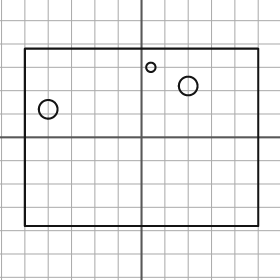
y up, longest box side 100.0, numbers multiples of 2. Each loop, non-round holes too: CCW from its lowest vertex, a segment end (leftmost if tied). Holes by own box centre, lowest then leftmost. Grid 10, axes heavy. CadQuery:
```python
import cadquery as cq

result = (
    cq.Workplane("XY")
    .moveTo(-50.0, -38.0)
    .lineTo(50.0, -38.0)
    .lineTo(50.0, 38.0)
    .lineTo(-50.0, 38.0)
    .close()
    .moveTo(-40.0, 12.0)
    .circle(4.0)
    .moveTo(20.0, 22.0)
    .circle(4.0)
    .moveTo(4.0, 30.0)
    .circle(2.0)
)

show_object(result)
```